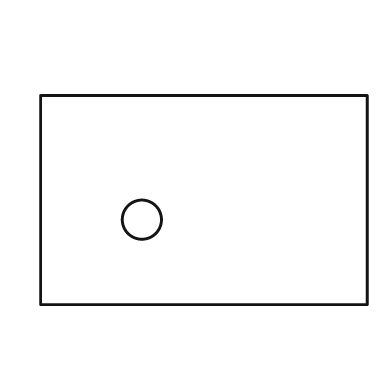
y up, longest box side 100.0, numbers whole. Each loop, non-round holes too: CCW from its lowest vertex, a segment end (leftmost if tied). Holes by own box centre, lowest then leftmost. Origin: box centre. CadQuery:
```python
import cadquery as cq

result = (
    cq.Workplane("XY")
    .moveTo(-50.0, -32.0)
    .lineTo(50.0, -32.0)
    .lineTo(50.0, 32.0)
    .lineTo(-50.0, 32.0)
    .close()
    .moveTo(-19.0, -6.0)
    .circle(6.0)
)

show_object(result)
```